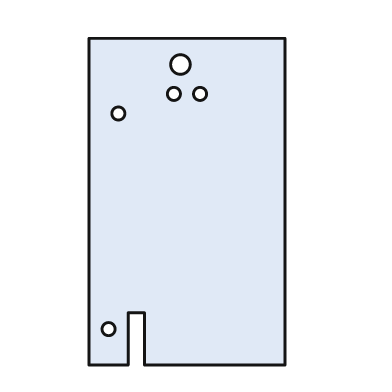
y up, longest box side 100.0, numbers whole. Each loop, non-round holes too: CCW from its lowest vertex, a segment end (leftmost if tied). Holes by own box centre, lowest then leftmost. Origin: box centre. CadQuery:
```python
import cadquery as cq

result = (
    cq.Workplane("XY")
    .moveTo(-30.0, -50.0)
    .lineTo(-18.0, -50.0)
    .lineTo(-18.0, -34.0)
    .lineTo(-13.0, -34.0)
    .lineTo(-13.0, -50.0)
    .lineTo(30.0, -50.0)
    .lineTo(30.0, 50.0)
    .lineTo(-30.0, 50.0)
    .close()
    .moveTo(-24.0, -39.0)
    .circle(2.0)
    .moveTo(-21.0, 27.0)
    .circle(2.0)
    .moveTo(-4.0, 33.0)
    .circle(2.0)
    .moveTo(4.0, 33.0)
    .circle(2.0)
    .moveTo(-2.0, 42.0)
    .circle(3.0)
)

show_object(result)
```